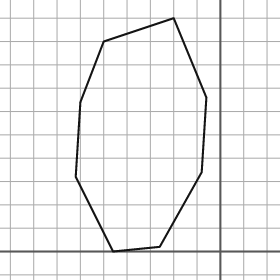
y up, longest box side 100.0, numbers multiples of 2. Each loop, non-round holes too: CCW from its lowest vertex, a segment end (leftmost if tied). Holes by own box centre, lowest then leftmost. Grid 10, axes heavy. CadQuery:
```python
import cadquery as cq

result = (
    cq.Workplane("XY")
    .moveTo(-46.0, 0.0)
    .lineTo(-26.0, 2.0)
    .lineTo(-8.0, 34.0)
    .lineTo(-6.0, 66.0)
    .lineTo(-20.0, 100.0)
    .lineTo(-50.0, 90.0)
    .lineTo(-60.0, 64.0)
    .lineTo(-62.0, 32.0)
    .close()
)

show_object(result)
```